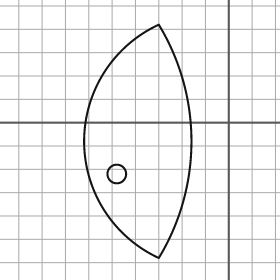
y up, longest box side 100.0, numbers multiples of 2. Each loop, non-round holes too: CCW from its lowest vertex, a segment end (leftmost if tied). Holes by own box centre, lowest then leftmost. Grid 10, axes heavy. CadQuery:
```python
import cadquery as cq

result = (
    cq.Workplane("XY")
    .moveTo(-30.0, -58.0)
    .threePointArc((-16.0, -8.0), (-30.0, 42.0))
    .threePointArc((-62.0, -8.0), (-30.0, -58.0))
    .close()
    .moveTo(-48.0, -22.0)
    .circle(4.0)
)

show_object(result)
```